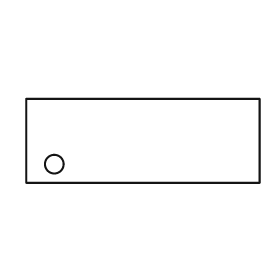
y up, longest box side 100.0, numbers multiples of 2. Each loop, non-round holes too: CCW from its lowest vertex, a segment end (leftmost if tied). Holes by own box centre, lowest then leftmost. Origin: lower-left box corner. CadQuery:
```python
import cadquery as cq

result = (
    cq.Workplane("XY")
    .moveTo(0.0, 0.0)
    .lineTo(100.0, 0.0)
    .lineTo(100.0, 36.0)
    .lineTo(0.0, 36.0)
    .close()
    .moveTo(12.0, 8.0)
    .circle(4.0)
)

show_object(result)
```